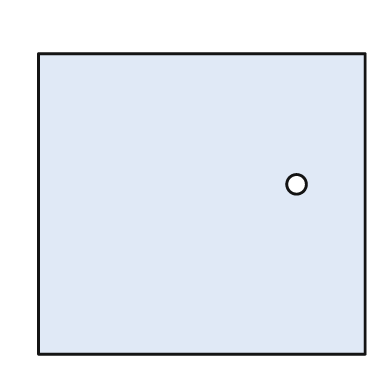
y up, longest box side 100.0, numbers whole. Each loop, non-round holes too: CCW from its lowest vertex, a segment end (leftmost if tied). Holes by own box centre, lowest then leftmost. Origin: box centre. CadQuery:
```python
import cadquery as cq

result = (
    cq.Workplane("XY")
    .moveTo(-50.0, -46.0)
    .lineTo(50.0, -46.0)
    .lineTo(50.0, 46.0)
    .lineTo(-50.0, 46.0)
    .close()
    .moveTo(29.0, 6.0)
    .circle(3.0)
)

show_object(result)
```